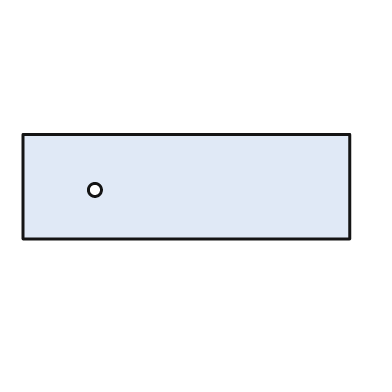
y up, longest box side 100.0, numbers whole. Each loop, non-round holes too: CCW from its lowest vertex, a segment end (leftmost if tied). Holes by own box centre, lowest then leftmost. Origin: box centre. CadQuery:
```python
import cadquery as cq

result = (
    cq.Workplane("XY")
    .moveTo(-50.0, -16.0)
    .lineTo(50.0, -16.0)
    .lineTo(50.0, 16.0)
    .lineTo(-50.0, 16.0)
    .close()
    .moveTo(-28.0, -1.0)
    .circle(2.0)
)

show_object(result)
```